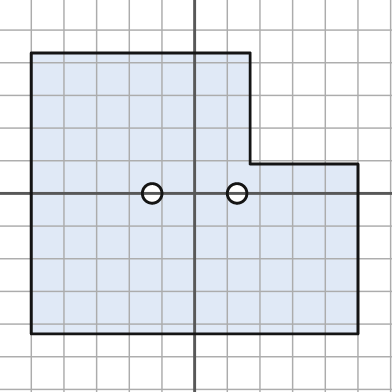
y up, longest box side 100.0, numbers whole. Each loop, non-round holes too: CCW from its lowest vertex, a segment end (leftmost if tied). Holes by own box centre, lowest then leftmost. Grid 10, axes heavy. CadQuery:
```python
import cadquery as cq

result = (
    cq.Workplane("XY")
    .moveTo(-50.0, -43.0)
    .lineTo(50.0, -43.0)
    .lineTo(50.0, 9.0)
    .lineTo(17.0, 9.0)
    .lineTo(17.0, 43.0)
    .lineTo(-50.0, 43.0)
    .close()
    .moveTo(-13.0, 0.0)
    .circle(3.0)
    .moveTo(13.0, 0.0)
    .circle(3.0)
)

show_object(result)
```